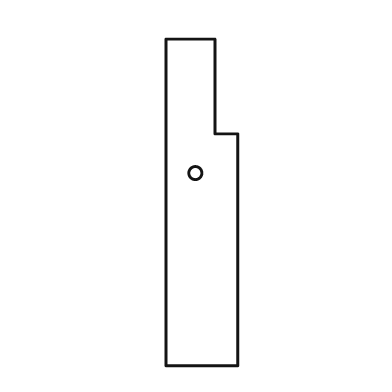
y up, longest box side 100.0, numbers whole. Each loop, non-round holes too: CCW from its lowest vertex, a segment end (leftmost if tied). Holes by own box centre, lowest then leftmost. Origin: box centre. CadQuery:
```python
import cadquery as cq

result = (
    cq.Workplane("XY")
    .moveTo(-11.0, -50.0)
    .lineTo(11.0, -50.0)
    .lineTo(11.0, 21.0)
    .lineTo(4.0, 21.0)
    .lineTo(4.0, 50.0)
    .lineTo(-11.0, 50.0)
    .close()
    .moveTo(-2.0, 9.0)
    .circle(2.0)
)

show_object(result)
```